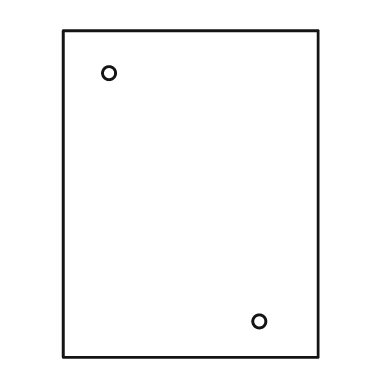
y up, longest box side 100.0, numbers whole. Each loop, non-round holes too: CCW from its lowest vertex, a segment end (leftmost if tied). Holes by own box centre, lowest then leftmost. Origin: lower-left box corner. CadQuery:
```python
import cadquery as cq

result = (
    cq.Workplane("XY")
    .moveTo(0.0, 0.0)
    .lineTo(78.0, 0.0)
    .lineTo(78.0, 100.0)
    .lineTo(0.0, 100.0)
    .close()
    .moveTo(60.0, 11.0)
    .circle(2.0)
    .moveTo(14.0, 87.0)
    .circle(2.0)
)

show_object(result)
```